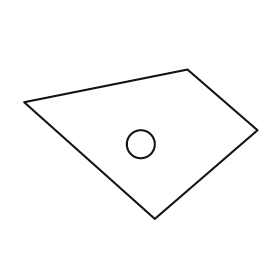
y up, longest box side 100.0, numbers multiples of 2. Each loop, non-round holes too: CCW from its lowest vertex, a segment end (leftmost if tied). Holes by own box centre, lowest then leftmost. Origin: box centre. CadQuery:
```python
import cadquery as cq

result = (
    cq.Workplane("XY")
    .moveTo(6.0, -32.0)
    .lineTo(50.0, 6.0)
    .lineTo(20.0, 32.0)
    .lineTo(-50.0, 18.0)
    .close()
    .moveTo(0.0, 0.0)
    .circle(6.0)
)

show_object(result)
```